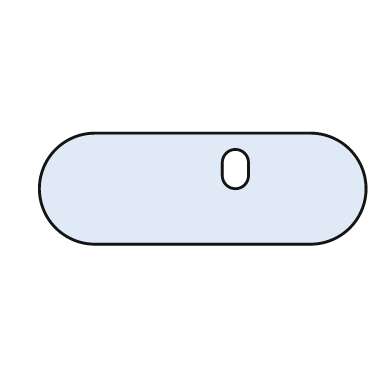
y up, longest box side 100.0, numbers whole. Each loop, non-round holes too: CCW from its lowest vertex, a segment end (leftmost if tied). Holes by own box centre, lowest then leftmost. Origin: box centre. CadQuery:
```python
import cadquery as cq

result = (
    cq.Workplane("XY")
    .moveTo(-33.0, -17.0)
    .lineTo(33.0, -17.0)
    .threePointArc((50.0, 0.0), (33.0, 17.0))
    .lineTo(-33.0, 17.0)
    .threePointArc((-50.0, 0.0), (-33.0, -17.0))
    .close()
    .moveTo(6.0, 4.0)
    .threePointArc((10.0, 0.0), (14.0, 4.0))
    .lineTo(14.0, 8.0)
    .threePointArc((10.0, 12.0), (6.0, 8.0))
    .close()
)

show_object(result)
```